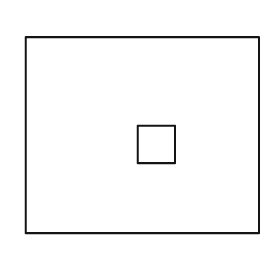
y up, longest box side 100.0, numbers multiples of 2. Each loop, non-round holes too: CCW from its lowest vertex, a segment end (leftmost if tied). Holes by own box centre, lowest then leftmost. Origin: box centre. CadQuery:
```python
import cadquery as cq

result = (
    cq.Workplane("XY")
    .moveTo(-50.0, -42.0)
    .lineTo(50.0, -42.0)
    .lineTo(50.0, 42.0)
    .lineTo(-50.0, 42.0)
    .close()
    .moveTo(-2.0, -12.0)
    .lineTo(14.0, -12.0)
    .lineTo(14.0, 4.0)
    .lineTo(-2.0, 4.0)
    .close()
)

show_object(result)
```